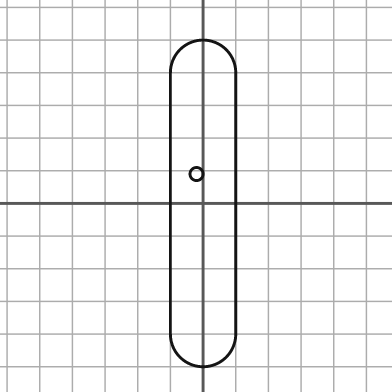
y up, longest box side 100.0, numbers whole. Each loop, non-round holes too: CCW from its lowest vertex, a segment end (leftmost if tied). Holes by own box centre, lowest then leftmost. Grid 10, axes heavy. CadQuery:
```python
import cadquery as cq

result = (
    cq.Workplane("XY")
    .moveTo(-10.0, -40.0)
    .threePointArc((0.0, -50.0), (10.0, -40.0))
    .lineTo(10.0, 40.0)
    .threePointArc((0.0, 50.0), (-10.0, 40.0))
    .close()
    .moveTo(-2.0, 9.0)
    .circle(2.0)
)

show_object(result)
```